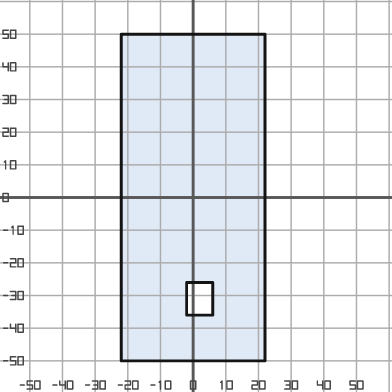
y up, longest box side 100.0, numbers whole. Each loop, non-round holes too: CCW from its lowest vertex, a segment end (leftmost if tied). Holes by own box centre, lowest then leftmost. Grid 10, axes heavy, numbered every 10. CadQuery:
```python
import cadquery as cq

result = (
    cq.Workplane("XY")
    .moveTo(-22.0, -50.0)
    .lineTo(22.0, -50.0)
    .lineTo(22.0, 50.0)
    .lineTo(-22.0, 50.0)
    .close()
    .moveTo(-2.0, -36.0)
    .lineTo(6.0, -36.0)
    .lineTo(6.0, -26.0)
    .lineTo(-2.0, -26.0)
    .close()
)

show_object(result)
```